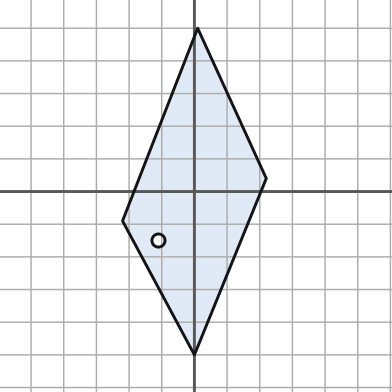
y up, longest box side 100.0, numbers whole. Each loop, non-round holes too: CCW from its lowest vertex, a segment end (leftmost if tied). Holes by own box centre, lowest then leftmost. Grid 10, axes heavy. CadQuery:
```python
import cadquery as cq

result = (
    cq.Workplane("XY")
    .moveTo(0.0, -50.0)
    .lineTo(22.0, 4.0)
    .lineTo(1.0, 50.0)
    .lineTo(-22.0, -9.0)
    .close()
    .moveTo(-11.0, -15.0)
    .circle(2.0)
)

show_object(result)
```